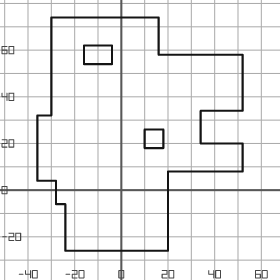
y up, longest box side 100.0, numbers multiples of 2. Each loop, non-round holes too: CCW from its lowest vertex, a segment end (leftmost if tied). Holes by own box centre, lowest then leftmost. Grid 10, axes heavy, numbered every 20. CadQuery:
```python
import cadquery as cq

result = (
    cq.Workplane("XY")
    .moveTo(-24.0, -26.0)
    .lineTo(20.0, -26.0)
    .lineTo(20.0, 8.0)
    .lineTo(52.0, 8.0)
    .lineTo(52.0, 20.0)
    .lineTo(34.0, 20.0)
    .lineTo(34.0, 34.0)
    .lineTo(52.0, 34.0)
    .lineTo(52.0, 58.0)
    .lineTo(16.0, 58.0)
    .lineTo(16.0, 74.0)
    .lineTo(-30.0, 74.0)
    .lineTo(-30.0, 32.0)
    .lineTo(-36.0, 32.0)
    .lineTo(-36.0, 4.0)
    .lineTo(-28.0, 4.0)
    .lineTo(-28.0, -6.0)
    .lineTo(-24.0, -6.0)
    .close()
    .moveTo(10.0, 18.0)
    .lineTo(18.0, 18.0)
    .lineTo(18.0, 26.0)
    .lineTo(10.0, 26.0)
    .close()
    .moveTo(-16.0, 54.0)
    .lineTo(-4.0, 54.0)
    .lineTo(-4.0, 62.0)
    .lineTo(-16.0, 62.0)
    .close()
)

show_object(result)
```